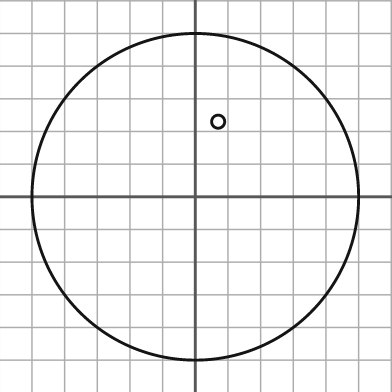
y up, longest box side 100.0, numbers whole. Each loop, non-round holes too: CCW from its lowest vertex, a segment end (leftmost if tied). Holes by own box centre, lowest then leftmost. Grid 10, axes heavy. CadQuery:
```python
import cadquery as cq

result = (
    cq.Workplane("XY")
    .moveTo(0.0, 0.0)
    .circle(50.0)
    .moveTo(7.0, 23.0)
    .circle(2.0)
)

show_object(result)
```